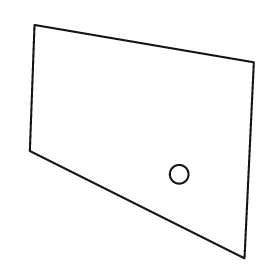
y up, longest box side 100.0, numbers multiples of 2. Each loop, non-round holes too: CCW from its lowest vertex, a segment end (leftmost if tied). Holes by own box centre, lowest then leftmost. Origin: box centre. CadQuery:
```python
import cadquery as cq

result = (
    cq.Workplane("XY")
    .moveTo(44.0, -50.0)
    .lineTo(48.0, 34.0)
    .lineTo(-46.0, 50.0)
    .lineTo(-48.0, -4.0)
    .close()
    .moveTo(16.0, -14.0)
    .circle(4.0)
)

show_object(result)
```